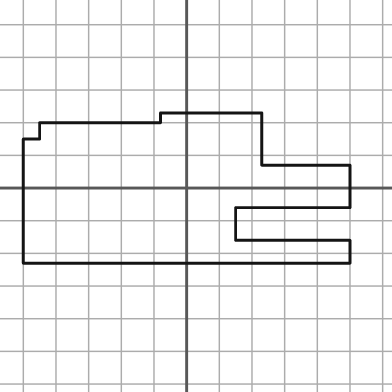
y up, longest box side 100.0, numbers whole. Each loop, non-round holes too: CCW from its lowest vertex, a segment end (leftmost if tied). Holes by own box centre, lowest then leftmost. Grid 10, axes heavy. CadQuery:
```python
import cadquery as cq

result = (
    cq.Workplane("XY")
    .moveTo(-50.0, -23.0)
    .lineTo(50.0, -23.0)
    .lineTo(50.0, -16.0)
    .lineTo(15.0, -16.0)
    .lineTo(15.0, -6.0)
    .lineTo(50.0, -6.0)
    .lineTo(50.0, 7.0)
    .lineTo(23.0, 7.0)
    .lineTo(23.0, 23.0)
    .lineTo(-8.0, 23.0)
    .lineTo(-8.0, 20.0)
    .lineTo(-45.0, 20.0)
    .lineTo(-45.0, 15.0)
    .lineTo(-50.0, 15.0)
    .close()
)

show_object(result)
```